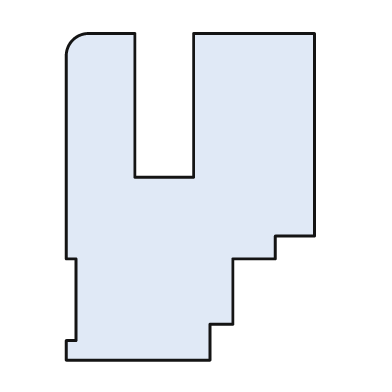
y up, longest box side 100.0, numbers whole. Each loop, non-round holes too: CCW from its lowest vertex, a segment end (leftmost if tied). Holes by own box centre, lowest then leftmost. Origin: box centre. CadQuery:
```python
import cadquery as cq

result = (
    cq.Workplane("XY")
    .moveTo(-38.0, -50.0)
    .lineTo(6.0, -50.0)
    .lineTo(6.0, -39.0)
    .lineTo(13.0, -39.0)
    .lineTo(13.0, -19.0)
    .lineTo(26.0, -19.0)
    .lineTo(26.0, -12.0)
    .lineTo(38.0, -12.0)
    .lineTo(38.0, 50.0)
    .lineTo(1.0, 50.0)
    .lineTo(1.0, 6.0)
    .lineTo(-17.0, 6.0)
    .lineTo(-17.0, 50.0)
    .lineTo(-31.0, 50.0)
    .threePointArc((-36.0, 48.0), (-38.0, 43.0))
    .lineTo(-38.0, -19.0)
    .lineTo(-35.0, -19.0)
    .lineTo(-35.0, -44.0)
    .lineTo(-38.0, -44.0)
    .close()
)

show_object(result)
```